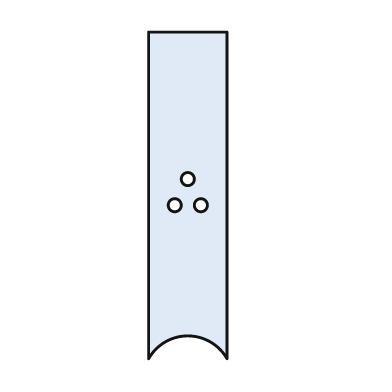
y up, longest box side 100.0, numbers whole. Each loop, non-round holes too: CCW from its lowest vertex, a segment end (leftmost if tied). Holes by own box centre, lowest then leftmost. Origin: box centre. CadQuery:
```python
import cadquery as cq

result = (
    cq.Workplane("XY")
    .moveTo(-12.0, -50.0)
    .threePointArc((0.0, -43.0), (12.0, -50.0))
    .lineTo(12.0, 50.0)
    .lineTo(-12.0, 50.0)
    .close()
    .moveTo(-4.0, -3.0)
    .circle(2.0)
    .moveTo(4.0, -3.0)
    .circle(2.0)
    .moveTo(0.0, 5.0)
    .circle(2.0)
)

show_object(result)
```